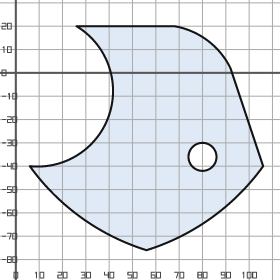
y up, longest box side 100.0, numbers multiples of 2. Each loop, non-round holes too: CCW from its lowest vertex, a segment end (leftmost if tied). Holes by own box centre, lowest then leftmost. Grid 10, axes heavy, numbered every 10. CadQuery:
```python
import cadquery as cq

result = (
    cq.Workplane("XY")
    .moveTo(56.0, -76.0)
    .threePointArc((84.0, -62.0), (106.0, -40.0))
    .lineTo(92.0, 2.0)
    .threePointArc((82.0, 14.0), (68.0, 20.0))
    .lineTo(26.0, 20.0)
    .threePointArc((40.0, -18.0), (6.0, -40.0))
    .threePointArc((28.0, -62.0), (56.0, -76.0))
    .close()
    .moveTo(80.0, -36.0)
    .circle(6.0)
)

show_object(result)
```